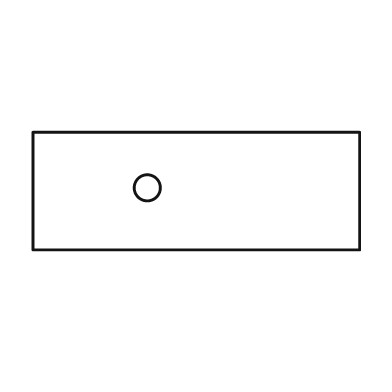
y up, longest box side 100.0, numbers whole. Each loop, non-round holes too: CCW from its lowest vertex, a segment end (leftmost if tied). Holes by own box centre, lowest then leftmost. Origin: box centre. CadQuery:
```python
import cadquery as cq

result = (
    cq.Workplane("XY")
    .moveTo(-50.0, -18.0)
    .lineTo(50.0, -18.0)
    .lineTo(50.0, 18.0)
    .lineTo(-50.0, 18.0)
    .close()
    .moveTo(-15.0, 1.0)
    .circle(4.0)
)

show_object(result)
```